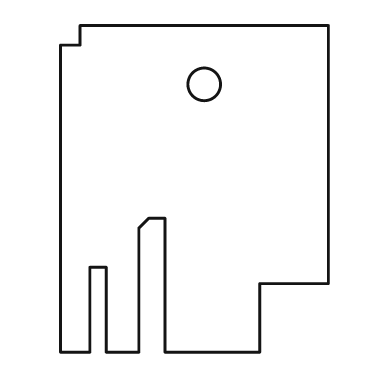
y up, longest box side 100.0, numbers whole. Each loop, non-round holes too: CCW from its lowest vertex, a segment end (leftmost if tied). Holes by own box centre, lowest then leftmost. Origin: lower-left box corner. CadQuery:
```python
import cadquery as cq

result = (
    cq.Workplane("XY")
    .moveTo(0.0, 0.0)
    .lineTo(9.0, 0.0)
    .lineTo(9.0, 26.0)
    .lineTo(14.0, 26.0)
    .lineTo(14.0, 0.0)
    .lineTo(24.0, 0.0)
    .lineTo(24.0, 38.0)
    .lineTo(27.0, 41.0)
    .lineTo(32.0, 41.0)
    .lineTo(32.0, 0.0)
    .lineTo(61.0, 0.0)
    .lineTo(61.0, 21.0)
    .lineTo(82.0, 21.0)
    .lineTo(82.0, 100.0)
    .lineTo(6.0, 100.0)
    .lineTo(6.0, 94.0)
    .lineTo(0.0, 94.0)
    .close()
    .moveTo(44.0, 82.0)
    .circle(5.0)
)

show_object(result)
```